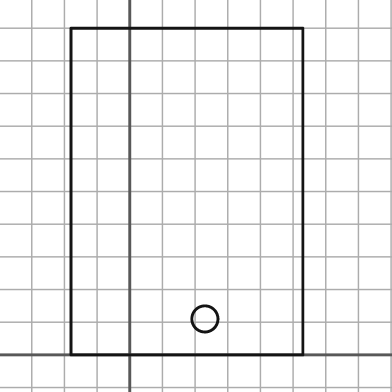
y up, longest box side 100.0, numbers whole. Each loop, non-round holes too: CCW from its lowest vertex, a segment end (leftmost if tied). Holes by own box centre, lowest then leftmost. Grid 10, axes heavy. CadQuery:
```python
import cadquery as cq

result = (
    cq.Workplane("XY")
    .moveTo(-18.0, 0.0)
    .lineTo(53.0, 0.0)
    .lineTo(53.0, 100.0)
    .lineTo(-18.0, 100.0)
    .close()
    .moveTo(23.0, 11.0)
    .circle(4.0)
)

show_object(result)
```